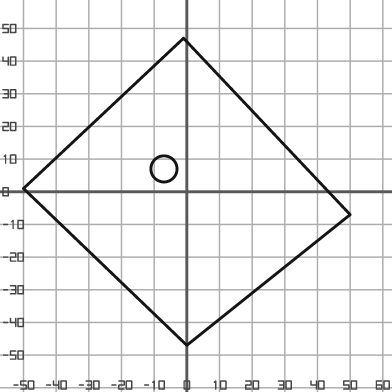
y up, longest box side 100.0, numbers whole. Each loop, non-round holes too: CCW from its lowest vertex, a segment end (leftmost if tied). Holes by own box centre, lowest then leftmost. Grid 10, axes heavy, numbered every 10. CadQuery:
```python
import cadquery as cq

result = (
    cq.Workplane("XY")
    .moveTo(0.0, -47.0)
    .lineTo(50.0, -7.0)
    .lineTo(-1.0, 47.0)
    .lineTo(-50.0, 1.0)
    .close()
    .moveTo(-7.0, 7.0)
    .circle(4.0)
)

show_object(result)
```